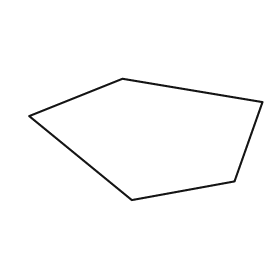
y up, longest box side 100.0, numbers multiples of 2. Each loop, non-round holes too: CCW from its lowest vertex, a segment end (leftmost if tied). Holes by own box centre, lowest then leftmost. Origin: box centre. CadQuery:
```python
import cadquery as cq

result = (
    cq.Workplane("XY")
    .moveTo(-6.0, -26.0)
    .lineTo(38.0, -18.0)
    .lineTo(50.0, 16.0)
    .lineTo(-10.0, 26.0)
    .lineTo(-50.0, 10.0)
    .close()
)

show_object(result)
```